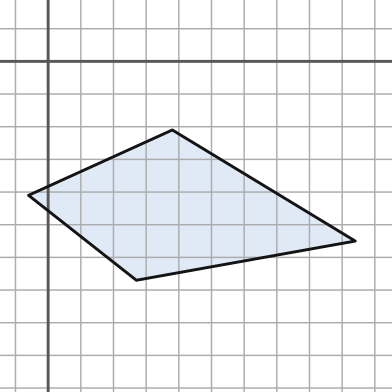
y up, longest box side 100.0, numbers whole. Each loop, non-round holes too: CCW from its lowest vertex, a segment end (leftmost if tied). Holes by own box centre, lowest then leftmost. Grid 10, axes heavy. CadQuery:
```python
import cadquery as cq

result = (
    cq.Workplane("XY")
    .moveTo(27.0, -67.0)
    .lineTo(94.0, -55.0)
    .lineTo(38.0, -21.0)
    .lineTo(-6.0, -41.0)
    .close()
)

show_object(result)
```